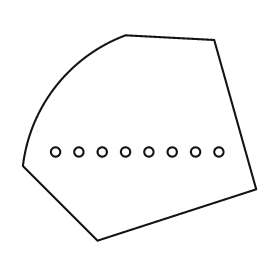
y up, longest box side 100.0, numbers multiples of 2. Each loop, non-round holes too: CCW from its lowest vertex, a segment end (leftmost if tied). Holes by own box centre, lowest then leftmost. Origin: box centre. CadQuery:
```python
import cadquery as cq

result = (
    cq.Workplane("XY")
    .moveTo(-18.0, -44.0)
    .lineTo(50.0, -22.0)
    .lineTo(32.0, 42.0)
    .lineTo(-6.0, 44.0)
    .threePointArc((-36.0, 22.0), (-50.0, -12.0))
    .close()
    .moveTo(-36.0, -6.0)
    .circle(2.0)
    .moveTo(-26.0, -6.0)
    .circle(2.0)
    .moveTo(-16.0, -6.0)
    .circle(2.0)
    .moveTo(-6.0, -6.0)
    .circle(2.0)
    .moveTo(4.0, -6.0)
    .circle(2.0)
    .moveTo(14.0, -6.0)
    .circle(2.0)
    .moveTo(24.0, -6.0)
    .circle(2.0)
    .moveTo(34.0, -6.0)
    .circle(2.0)
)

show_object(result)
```